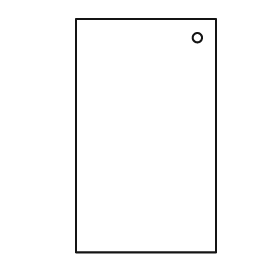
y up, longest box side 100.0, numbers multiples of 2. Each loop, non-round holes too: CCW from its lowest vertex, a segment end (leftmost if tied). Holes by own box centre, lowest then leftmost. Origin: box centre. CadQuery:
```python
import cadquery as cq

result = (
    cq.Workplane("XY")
    .moveTo(-30.0, -50.0)
    .lineTo(30.0, -50.0)
    .lineTo(30.0, 50.0)
    .lineTo(-30.0, 50.0)
    .close()
    .moveTo(22.0, 42.0)
    .circle(2.0)
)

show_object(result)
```